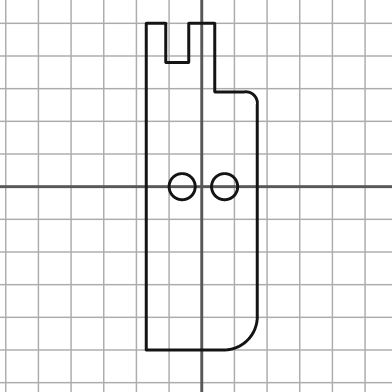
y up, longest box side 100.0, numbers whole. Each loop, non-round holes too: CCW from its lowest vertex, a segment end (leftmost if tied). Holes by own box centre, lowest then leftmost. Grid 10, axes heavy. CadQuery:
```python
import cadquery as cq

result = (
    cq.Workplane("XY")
    .moveTo(-17.0, -50.0)
    .lineTo(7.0, -50.0)
    .threePointArc((14.0, -47.0), (17.0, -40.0))
    .lineTo(17.0, 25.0)
    .threePointArc((16.0, 28.0), (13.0, 29.0))
    .lineTo(4.0, 29.0)
    .lineTo(4.0, 50.0)
    .lineTo(-4.0, 50.0)
    .lineTo(-4.0, 38.0)
    .lineTo(-11.0, 38.0)
    .lineTo(-11.0, 50.0)
    .lineTo(-17.0, 50.0)
    .close()
    .moveTo(-6.0, 0.0)
    .circle(4.0)
    .moveTo(7.0, 0.0)
    .circle(4.0)
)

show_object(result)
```